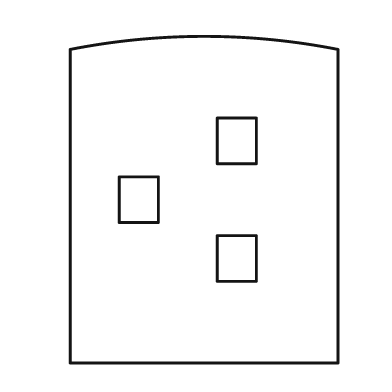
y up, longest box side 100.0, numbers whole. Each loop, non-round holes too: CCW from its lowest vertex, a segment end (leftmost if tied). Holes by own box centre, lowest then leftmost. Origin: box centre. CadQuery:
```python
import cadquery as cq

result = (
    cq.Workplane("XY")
    .moveTo(-41.0, -50.0)
    .lineTo(41.0, -50.0)
    .lineTo(41.0, 46.0)
    .threePointArc((0.0, 50.0), (-41.0, 46.0))
    .close()
    .moveTo(4.0, -25.0)
    .lineTo(16.0, -25.0)
    .lineTo(16.0, -11.0)
    .lineTo(4.0, -11.0)
    .close()
    .moveTo(-26.0, -7.0)
    .lineTo(-14.0, -7.0)
    .lineTo(-14.0, 7.0)
    .lineTo(-26.0, 7.0)
    .close()
    .moveTo(4.0, 11.0)
    .lineTo(16.0, 11.0)
    .lineTo(16.0, 25.0)
    .lineTo(4.0, 25.0)
    .close()
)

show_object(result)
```